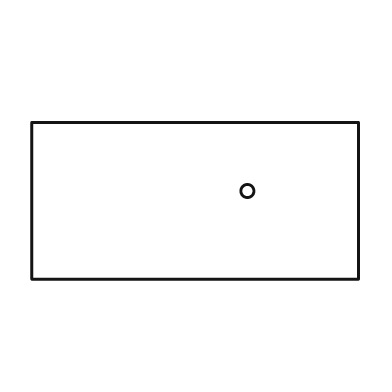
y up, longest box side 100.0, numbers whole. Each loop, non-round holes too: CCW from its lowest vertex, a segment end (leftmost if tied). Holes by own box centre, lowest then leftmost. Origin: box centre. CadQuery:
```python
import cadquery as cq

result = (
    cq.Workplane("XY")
    .moveTo(-50.0, -24.0)
    .lineTo(50.0, -24.0)
    .lineTo(50.0, 24.0)
    .lineTo(-50.0, 24.0)
    .close()
    .moveTo(16.0, 3.0)
    .circle(2.0)
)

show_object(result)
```